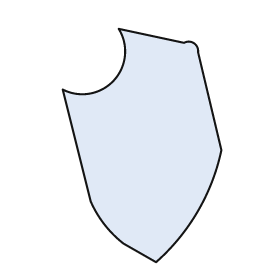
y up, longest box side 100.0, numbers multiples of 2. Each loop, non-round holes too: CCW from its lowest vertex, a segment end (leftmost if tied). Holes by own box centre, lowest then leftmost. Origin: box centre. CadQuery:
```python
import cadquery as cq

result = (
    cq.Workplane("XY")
    .moveTo(6.0, -50.0)
    .threePointArc((24.0, -28.0), (34.0, -2.0))
    .lineTo(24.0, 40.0)
    .threePointArc((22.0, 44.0), (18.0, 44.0))
    .lineTo(-10.0, 50.0)
    .threePointArc((-12.0, 28.0), (-34.0, 24.0))
    .lineTo(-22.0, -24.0)
    .threePointArc((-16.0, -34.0), (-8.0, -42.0))
    .close()
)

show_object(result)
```